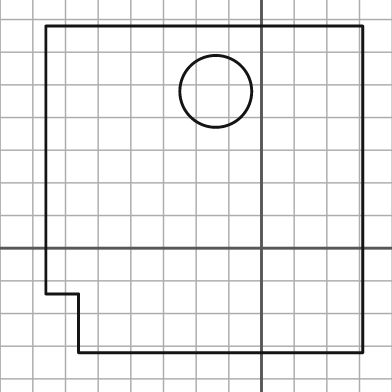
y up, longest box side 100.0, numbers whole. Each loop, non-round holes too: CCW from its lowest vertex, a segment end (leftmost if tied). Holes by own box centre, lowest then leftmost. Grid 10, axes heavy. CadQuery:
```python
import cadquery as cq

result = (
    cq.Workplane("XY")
    .moveTo(-56.0, -32.0)
    .lineTo(31.0, -32.0)
    .lineTo(31.0, 68.0)
    .lineTo(-66.0, 68.0)
    .lineTo(-66.0, -14.0)
    .lineTo(-56.0, -14.0)
    .close()
    .moveTo(-14.0, 48.0)
    .circle(11.0)
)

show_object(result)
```